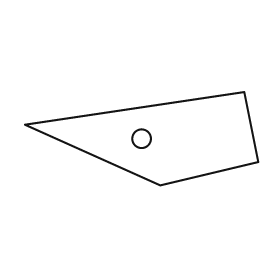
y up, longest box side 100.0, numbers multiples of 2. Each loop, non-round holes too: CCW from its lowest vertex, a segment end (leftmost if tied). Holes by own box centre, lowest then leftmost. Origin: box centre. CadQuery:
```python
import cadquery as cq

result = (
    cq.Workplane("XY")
    .moveTo(8.0, -20.0)
    .lineTo(50.0, -10.0)
    .lineTo(44.0, 20.0)
    .lineTo(-50.0, 6.0)
    .close()
    .moveTo(0.0, 0.0)
    .circle(4.0)
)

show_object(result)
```